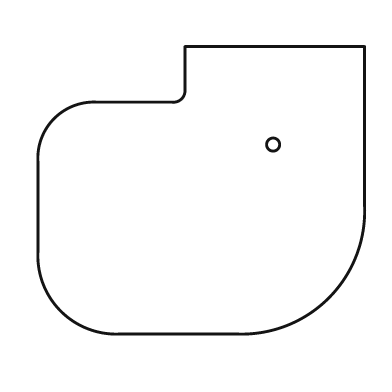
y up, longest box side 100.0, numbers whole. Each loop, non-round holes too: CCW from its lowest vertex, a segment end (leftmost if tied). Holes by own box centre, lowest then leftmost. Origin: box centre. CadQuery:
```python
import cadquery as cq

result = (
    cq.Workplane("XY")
    .moveTo(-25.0, -44.0)
    .lineTo(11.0, -44.0)
    .threePointArc((39.0, -33.0), (50.0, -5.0))
    .lineTo(50.0, 44.0)
    .lineTo(-5.0, 44.0)
    .lineTo(-5.0, 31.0)
    .threePointArc((-6.0, 28.0), (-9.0, 27.0))
    .lineTo(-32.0, 27.0)
    .threePointArc((-45.0, 22.0), (-50.0, 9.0))
    .lineTo(-50.0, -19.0)
    .threePointArc((-43.0, -37.0), (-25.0, -44.0))
    .close()
    .moveTo(22.0, 14.0)
    .circle(2.0)
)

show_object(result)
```